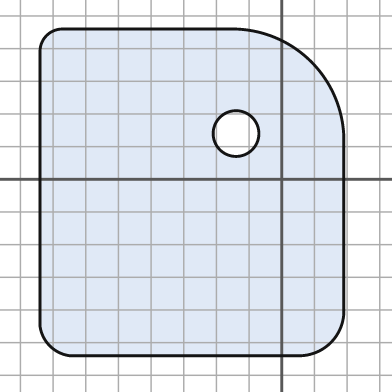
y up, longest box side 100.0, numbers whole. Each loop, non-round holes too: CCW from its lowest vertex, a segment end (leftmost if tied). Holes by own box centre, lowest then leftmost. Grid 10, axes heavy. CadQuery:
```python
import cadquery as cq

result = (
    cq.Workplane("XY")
    .moveTo(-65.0, -54.0)
    .lineTo(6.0, -54.0)
    .threePointArc((15.0, -50.0), (19.0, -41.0))
    .lineTo(19.0, 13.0)
    .threePointArc((9.0, 36.0), (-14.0, 46.0))
    .lineTo(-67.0, 46.0)
    .threePointArc((-72.0, 44.0), (-74.0, 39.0))
    .lineTo(-74.0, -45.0)
    .threePointArc((-71.0, -51.0), (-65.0, -54.0))
    .close()
    .moveTo(-14.0, 14.0)
    .circle(7.0)
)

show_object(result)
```